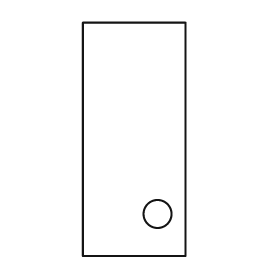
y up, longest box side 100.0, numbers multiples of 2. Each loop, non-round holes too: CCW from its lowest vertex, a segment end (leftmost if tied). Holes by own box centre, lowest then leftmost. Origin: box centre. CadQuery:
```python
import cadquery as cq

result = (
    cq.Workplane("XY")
    .moveTo(-22.0, -50.0)
    .lineTo(22.0, -50.0)
    .lineTo(22.0, 50.0)
    .lineTo(-22.0, 50.0)
    .close()
    .moveTo(10.0, -32.0)
    .circle(6.0)
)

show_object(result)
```